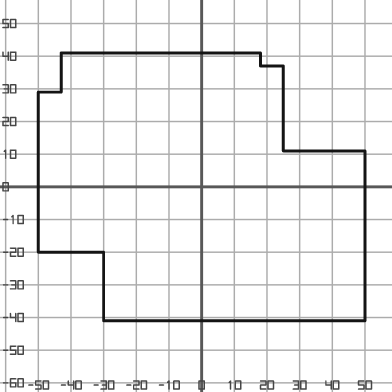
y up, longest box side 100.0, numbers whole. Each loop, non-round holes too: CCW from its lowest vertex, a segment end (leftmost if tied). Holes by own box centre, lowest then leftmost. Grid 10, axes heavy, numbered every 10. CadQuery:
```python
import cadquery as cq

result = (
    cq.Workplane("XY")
    .moveTo(-30.0, -41.0)
    .lineTo(50.0, -41.0)
    .lineTo(50.0, 11.0)
    .lineTo(25.0, 11.0)
    .lineTo(25.0, 37.0)
    .lineTo(18.0, 37.0)
    .lineTo(18.0, 41.0)
    .lineTo(-43.0, 41.0)
    .lineTo(-43.0, 29.0)
    .lineTo(-50.0, 29.0)
    .lineTo(-50.0, -20.0)
    .lineTo(-30.0, -20.0)
    .close()
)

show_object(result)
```